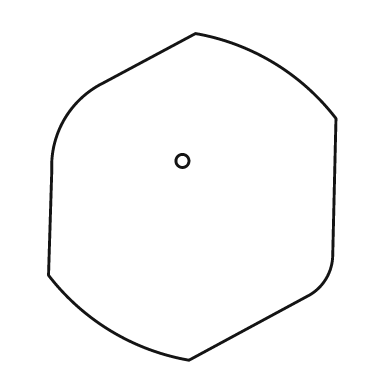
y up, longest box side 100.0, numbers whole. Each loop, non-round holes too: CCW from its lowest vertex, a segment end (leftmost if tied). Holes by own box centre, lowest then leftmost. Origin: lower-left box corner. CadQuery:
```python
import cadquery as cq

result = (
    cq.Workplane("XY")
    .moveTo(43.0, 0.0)
    .lineTo(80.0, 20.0)
    .threePointArc((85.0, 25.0), (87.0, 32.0))
    .lineTo(88.0, 74.0)
    .threePointArc((69.0, 91.0), (45.0, 100.0))
    .lineTo(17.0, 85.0)
    .threePointArc((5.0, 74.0), (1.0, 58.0))
    .lineTo(0.0, 26.0)
    .threePointArc((19.0, 9.0), (43.0, 0.0))
    .close()
    .moveTo(41.0, 61.0)
    .circle(2.0)
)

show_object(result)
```